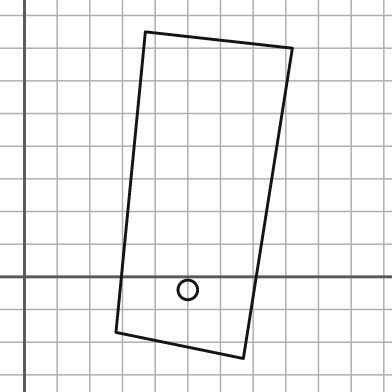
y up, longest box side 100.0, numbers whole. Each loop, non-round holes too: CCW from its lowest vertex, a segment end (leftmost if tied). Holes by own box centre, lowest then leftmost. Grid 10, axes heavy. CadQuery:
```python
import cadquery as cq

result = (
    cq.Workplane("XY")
    .moveTo(67.0, -25.0)
    .lineTo(82.0, 70.0)
    .lineTo(37.0, 75.0)
    .lineTo(28.0, -17.0)
    .close()
    .moveTo(50.0, -4.0)
    .circle(3.0)
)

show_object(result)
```